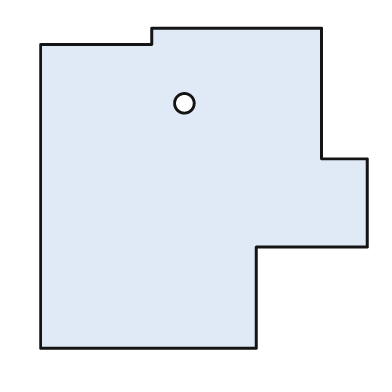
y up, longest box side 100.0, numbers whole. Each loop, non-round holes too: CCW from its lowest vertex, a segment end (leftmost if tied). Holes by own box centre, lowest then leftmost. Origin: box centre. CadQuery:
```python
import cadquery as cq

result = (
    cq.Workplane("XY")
    .moveTo(-50.0, -49.0)
    .lineTo(16.0, -49.0)
    .lineTo(16.0, -18.0)
    .lineTo(50.0, -18.0)
    .lineTo(50.0, 9.0)
    .lineTo(36.0, 9.0)
    .lineTo(36.0, 49.0)
    .lineTo(-16.0, 49.0)
    .lineTo(-16.0, 44.0)
    .lineTo(-50.0, 44.0)
    .close()
    .moveTo(-6.0, 26.0)
    .circle(3.0)
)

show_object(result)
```